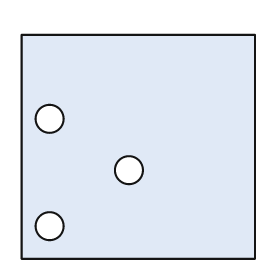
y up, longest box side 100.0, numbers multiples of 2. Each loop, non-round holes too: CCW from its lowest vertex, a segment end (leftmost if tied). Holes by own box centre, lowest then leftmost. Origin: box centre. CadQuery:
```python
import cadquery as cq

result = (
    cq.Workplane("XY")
    .moveTo(-50.0, -48.0)
    .lineTo(50.0, -48.0)
    .lineTo(50.0, 48.0)
    .lineTo(-50.0, 48.0)
    .close()
    .moveTo(-38.0, -34.0)
    .circle(6.0)
    .moveTo(-4.0, -10.0)
    .circle(6.0)
    .moveTo(-38.0, 12.0)
    .circle(6.0)
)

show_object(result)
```